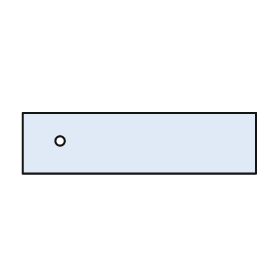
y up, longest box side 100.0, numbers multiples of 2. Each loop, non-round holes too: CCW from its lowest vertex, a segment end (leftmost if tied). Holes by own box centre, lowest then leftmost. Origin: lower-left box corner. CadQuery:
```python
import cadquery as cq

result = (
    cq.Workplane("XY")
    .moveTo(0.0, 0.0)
    .lineTo(100.0, 0.0)
    .lineTo(100.0, 26.0)
    .lineTo(0.0, 26.0)
    .close()
    .moveTo(16.0, 14.0)
    .circle(2.0)
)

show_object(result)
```